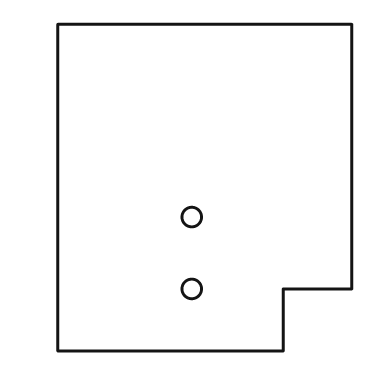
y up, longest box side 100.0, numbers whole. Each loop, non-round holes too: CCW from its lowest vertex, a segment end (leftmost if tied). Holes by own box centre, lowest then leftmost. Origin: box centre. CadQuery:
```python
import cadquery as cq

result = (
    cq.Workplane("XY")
    .moveTo(-45.0, -50.0)
    .lineTo(24.0, -50.0)
    .lineTo(24.0, -31.0)
    .lineTo(45.0, -31.0)
    .lineTo(45.0, 50.0)
    .lineTo(-45.0, 50.0)
    .close()
    .moveTo(-4.0, -31.0)
    .circle(3.0)
    .moveTo(-4.0, -9.0)
    .circle(3.0)
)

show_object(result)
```